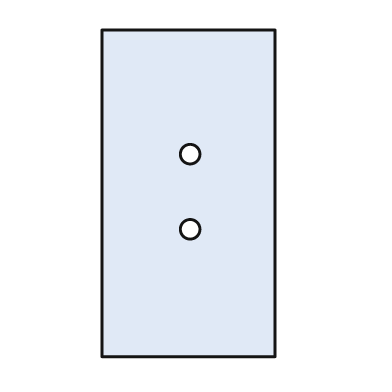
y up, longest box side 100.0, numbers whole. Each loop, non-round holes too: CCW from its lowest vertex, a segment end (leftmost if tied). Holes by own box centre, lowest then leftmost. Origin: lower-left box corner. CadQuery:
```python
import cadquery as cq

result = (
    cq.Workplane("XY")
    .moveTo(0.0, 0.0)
    .lineTo(53.0, 0.0)
    .lineTo(53.0, 100.0)
    .lineTo(0.0, 100.0)
    .close()
    .moveTo(27.0, 39.0)
    .circle(3.0)
    .moveTo(27.0, 62.0)
    .circle(3.0)
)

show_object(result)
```